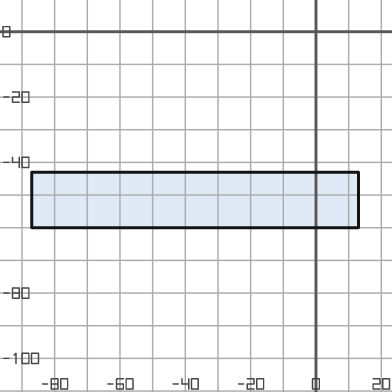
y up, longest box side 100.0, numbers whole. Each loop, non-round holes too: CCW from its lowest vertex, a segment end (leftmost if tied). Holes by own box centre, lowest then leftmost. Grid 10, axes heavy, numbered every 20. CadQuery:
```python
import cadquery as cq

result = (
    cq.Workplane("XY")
    .moveTo(-87.0, -60.0)
    .lineTo(13.0, -60.0)
    .lineTo(13.0, -43.0)
    .lineTo(-87.0, -43.0)
    .close()
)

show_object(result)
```